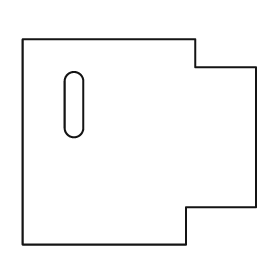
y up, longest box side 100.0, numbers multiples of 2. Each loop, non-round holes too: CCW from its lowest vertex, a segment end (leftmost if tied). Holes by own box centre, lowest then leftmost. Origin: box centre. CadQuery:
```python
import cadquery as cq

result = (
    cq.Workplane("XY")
    .moveTo(-50.0, -44.0)
    .lineTo(20.0, -44.0)
    .lineTo(20.0, -28.0)
    .lineTo(50.0, -28.0)
    .lineTo(50.0, 32.0)
    .lineTo(24.0, 32.0)
    .lineTo(24.0, 44.0)
    .lineTo(-50.0, 44.0)
    .close()
    .moveTo(-32.0, 6.0)
    .threePointArc((-28.0, 2.0), (-24.0, 6.0))
    .lineTo(-24.0, 26.0)
    .threePointArc((-28.0, 30.0), (-32.0, 26.0))
    .close()
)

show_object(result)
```